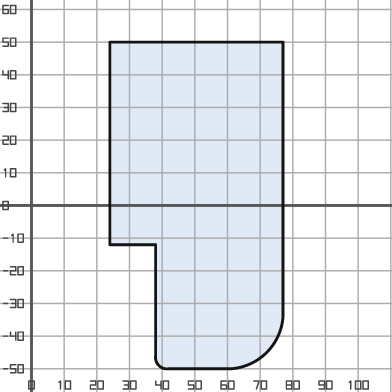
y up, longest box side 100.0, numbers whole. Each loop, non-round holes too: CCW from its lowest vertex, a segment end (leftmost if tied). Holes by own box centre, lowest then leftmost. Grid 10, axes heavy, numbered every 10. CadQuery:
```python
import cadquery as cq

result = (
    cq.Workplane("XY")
    .moveTo(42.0, -50.0)
    .lineTo(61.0, -50.0)
    .threePointArc((72.0, -45.0), (77.0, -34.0))
    .lineTo(77.0, 50.0)
    .lineTo(24.0, 50.0)
    .lineTo(24.0, -12.0)
    .lineTo(38.0, -12.0)
    .lineTo(38.0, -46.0)
    .threePointArc((39.0, -49.0), (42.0, -50.0))
    .close()
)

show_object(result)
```